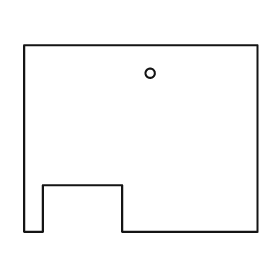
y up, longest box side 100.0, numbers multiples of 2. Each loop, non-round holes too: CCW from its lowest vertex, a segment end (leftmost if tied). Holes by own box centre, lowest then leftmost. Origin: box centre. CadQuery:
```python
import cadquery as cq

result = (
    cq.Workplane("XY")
    .moveTo(-50.0, -40.0)
    .lineTo(-42.0, -40.0)
    .lineTo(-42.0, -20.0)
    .lineTo(-8.0, -20.0)
    .lineTo(-8.0, -40.0)
    .lineTo(50.0, -40.0)
    .lineTo(50.0, 40.0)
    .lineTo(-50.0, 40.0)
    .close()
    .moveTo(4.0, 28.0)
    .circle(2.0)
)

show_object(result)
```